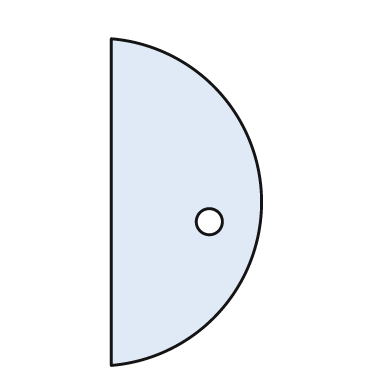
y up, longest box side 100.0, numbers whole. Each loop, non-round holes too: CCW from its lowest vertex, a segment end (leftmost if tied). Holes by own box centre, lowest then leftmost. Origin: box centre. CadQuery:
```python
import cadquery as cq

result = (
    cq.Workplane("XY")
    .moveTo(-23.0, -50.0)
    .threePointArc((23.0, 0.0), (-23.0, 50.0))
    .close()
    .moveTo(7.0, -6.0)
    .circle(4.0)
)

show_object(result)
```